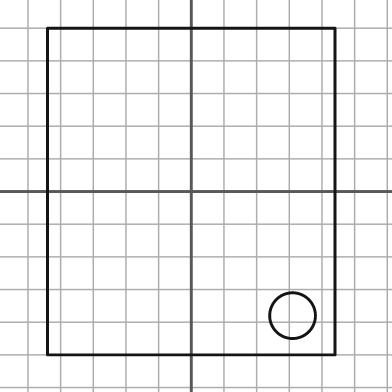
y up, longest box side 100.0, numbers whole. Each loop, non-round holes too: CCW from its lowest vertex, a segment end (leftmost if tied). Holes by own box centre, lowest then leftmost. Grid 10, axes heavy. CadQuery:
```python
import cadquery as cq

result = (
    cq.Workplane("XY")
    .moveTo(-44.0, -50.0)
    .lineTo(44.0, -50.0)
    .lineTo(44.0, 50.0)
    .lineTo(-44.0, 50.0)
    .close()
    .moveTo(31.0, -38.0)
    .circle(7.0)
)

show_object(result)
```